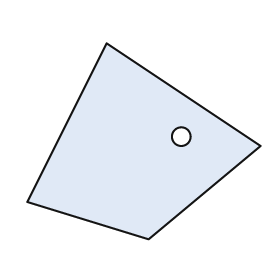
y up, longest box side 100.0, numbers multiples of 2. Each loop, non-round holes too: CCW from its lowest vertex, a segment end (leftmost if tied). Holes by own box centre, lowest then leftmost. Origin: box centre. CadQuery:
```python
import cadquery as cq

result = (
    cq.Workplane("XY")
    .moveTo(2.0, -42.0)
    .lineTo(50.0, -2.0)
    .lineTo(-16.0, 42.0)
    .lineTo(-50.0, -26.0)
    .close()
    .moveTo(16.0, 2.0)
    .circle(4.0)
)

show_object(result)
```